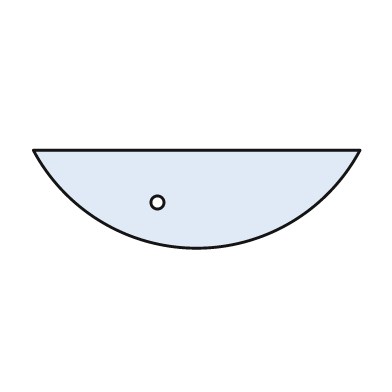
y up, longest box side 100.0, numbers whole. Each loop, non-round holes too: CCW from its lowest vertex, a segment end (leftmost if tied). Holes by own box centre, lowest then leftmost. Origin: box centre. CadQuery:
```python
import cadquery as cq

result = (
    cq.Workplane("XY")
    .moveTo(-50.0, 15.0)
    .threePointArc((0.0, -15.0), (50.0, 15.0))
    .close()
    .moveTo(-12.0, -1.0)
    .circle(2.0)
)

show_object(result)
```